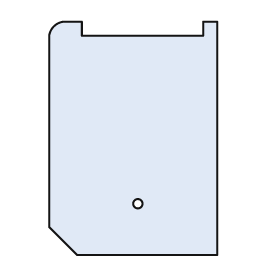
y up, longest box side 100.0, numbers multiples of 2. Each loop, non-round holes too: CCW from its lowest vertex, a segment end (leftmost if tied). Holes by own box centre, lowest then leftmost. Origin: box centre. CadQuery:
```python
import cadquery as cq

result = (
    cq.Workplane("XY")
    .moveTo(-24.0, -50.0)
    .lineTo(36.0, -50.0)
    .lineTo(36.0, 50.0)
    .lineTo(30.0, 50.0)
    .lineTo(30.0, 44.0)
    .lineTo(-22.0, 44.0)
    .lineTo(-22.0, 50.0)
    .lineTo(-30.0, 50.0)
    .threePointArc((-34.0, 48.0), (-36.0, 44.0))
    .lineTo(-36.0, -38.0)
    .close()
    .moveTo(2.0, -28.0)
    .circle(2.0)
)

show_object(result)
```